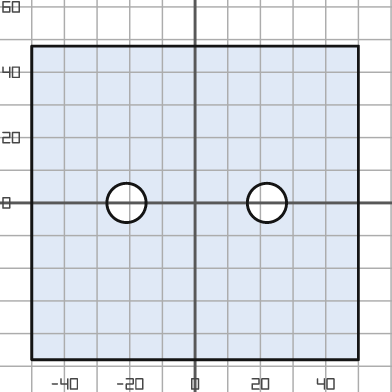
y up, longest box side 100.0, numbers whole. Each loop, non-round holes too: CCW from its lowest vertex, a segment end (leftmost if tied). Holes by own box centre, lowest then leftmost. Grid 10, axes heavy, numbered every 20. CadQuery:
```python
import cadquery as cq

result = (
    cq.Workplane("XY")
    .moveTo(-50.0, -48.0)
    .lineTo(50.0, -48.0)
    .lineTo(50.0, 48.0)
    .lineTo(-50.0, 48.0)
    .close()
    .moveTo(-21.0, 0.0)
    .circle(6.0)
    .moveTo(22.0, 0.0)
    .circle(6.0)
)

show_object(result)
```